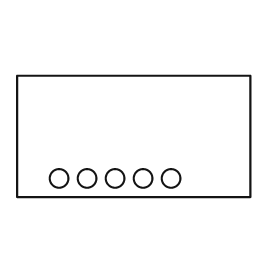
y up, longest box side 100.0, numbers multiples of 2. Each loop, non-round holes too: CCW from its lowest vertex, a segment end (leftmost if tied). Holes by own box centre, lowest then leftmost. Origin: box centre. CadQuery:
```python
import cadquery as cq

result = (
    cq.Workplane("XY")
    .moveTo(-50.0, -26.0)
    .lineTo(50.0, -26.0)
    .lineTo(50.0, 26.0)
    .lineTo(-50.0, 26.0)
    .close()
    .moveTo(-32.0, -18.0)
    .circle(4.0)
    .moveTo(-20.0, -18.0)
    .circle(4.0)
    .moveTo(-8.0, -18.0)
    .circle(4.0)
    .moveTo(4.0, -18.0)
    .circle(4.0)
    .moveTo(16.0, -18.0)
    .circle(4.0)
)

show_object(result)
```